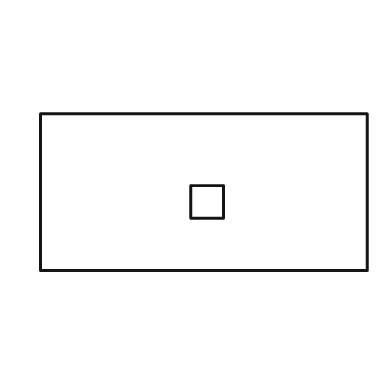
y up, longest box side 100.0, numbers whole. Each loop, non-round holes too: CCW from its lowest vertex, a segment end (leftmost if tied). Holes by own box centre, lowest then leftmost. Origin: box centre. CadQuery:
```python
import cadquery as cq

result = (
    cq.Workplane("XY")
    .moveTo(-50.0, -24.0)
    .lineTo(50.0, -24.0)
    .lineTo(50.0, 24.0)
    .lineTo(-50.0, 24.0)
    .close()
    .moveTo(-4.0, -8.0)
    .lineTo(6.0, -8.0)
    .lineTo(6.0, 2.0)
    .lineTo(-4.0, 2.0)
    .close()
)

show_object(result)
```